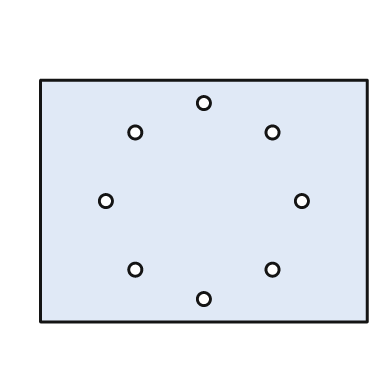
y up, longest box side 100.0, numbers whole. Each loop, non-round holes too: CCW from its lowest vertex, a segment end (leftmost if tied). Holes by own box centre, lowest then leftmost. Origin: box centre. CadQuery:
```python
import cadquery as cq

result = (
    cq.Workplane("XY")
    .moveTo(-50.0, -37.0)
    .lineTo(50.0, -37.0)
    .lineTo(50.0, 37.0)
    .lineTo(-50.0, 37.0)
    .close()
    .moveTo(0.0, -30.0)
    .circle(2.0)
    .moveTo(-21.0, -21.0)
    .circle(2.0)
    .moveTo(21.0, -21.0)
    .circle(2.0)
    .moveTo(-30.0, 0.0)
    .circle(2.0)
    .moveTo(30.0, 0.0)
    .circle(2.0)
    .moveTo(-21.0, 21.0)
    .circle(2.0)
    .moveTo(21.0, 21.0)
    .circle(2.0)
    .moveTo(0.0, 30.0)
    .circle(2.0)
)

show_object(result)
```